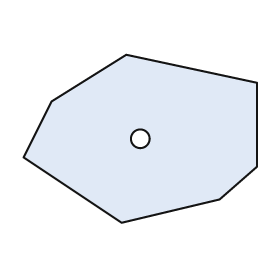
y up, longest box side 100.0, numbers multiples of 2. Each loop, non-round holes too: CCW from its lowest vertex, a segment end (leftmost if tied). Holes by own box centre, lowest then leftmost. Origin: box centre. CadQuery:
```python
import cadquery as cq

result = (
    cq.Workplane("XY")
    .moveTo(-8.0, -36.0)
    .lineTo(34.0, -26.0)
    .lineTo(50.0, -12.0)
    .lineTo(50.0, 24.0)
    .lineTo(-6.0, 36.0)
    .lineTo(-38.0, 16.0)
    .lineTo(-50.0, -8.0)
    .close()
    .moveTo(0.0, 0.0)
    .circle(4.0)
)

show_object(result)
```